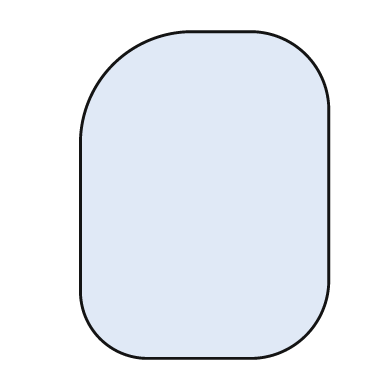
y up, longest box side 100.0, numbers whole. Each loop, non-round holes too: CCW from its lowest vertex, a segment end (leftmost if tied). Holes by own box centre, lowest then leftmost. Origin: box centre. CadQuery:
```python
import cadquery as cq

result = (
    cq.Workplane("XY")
    .moveTo(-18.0, -50.0)
    .lineTo(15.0, -50.0)
    .threePointArc((31.0, -43.0), (38.0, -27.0))
    .lineTo(38.0, 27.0)
    .threePointArc((31.0, 43.0), (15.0, 50.0))
    .lineTo(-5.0, 50.0)
    .threePointArc((-28.0, 40.0), (-38.0, 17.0))
    .lineTo(-38.0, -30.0)
    .threePointArc((-32.0, -44.0), (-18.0, -50.0))
    .close()
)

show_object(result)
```